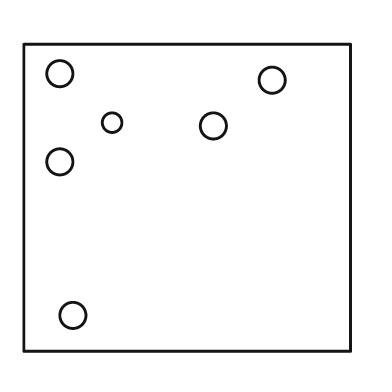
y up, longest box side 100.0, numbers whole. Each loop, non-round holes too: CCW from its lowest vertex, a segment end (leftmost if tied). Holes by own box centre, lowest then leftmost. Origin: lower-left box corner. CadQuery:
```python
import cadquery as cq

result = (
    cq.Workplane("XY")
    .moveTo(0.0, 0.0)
    .lineTo(100.0, 0.0)
    .lineTo(100.0, 94.0)
    .lineTo(0.0, 94.0)
    .close()
    .moveTo(15.0, 11.0)
    .circle(4.0)
    .moveTo(11.0, 58.0)
    .circle(4.0)
    .moveTo(58.0, 69.0)
    .circle(4.0)
    .moveTo(27.0, 70.0)
    .circle(3.0)
    .moveTo(76.0, 83.0)
    .circle(4.0)
    .moveTo(11.0, 85.0)
    .circle(4.0)
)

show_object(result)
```